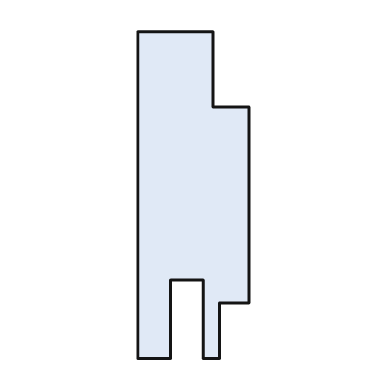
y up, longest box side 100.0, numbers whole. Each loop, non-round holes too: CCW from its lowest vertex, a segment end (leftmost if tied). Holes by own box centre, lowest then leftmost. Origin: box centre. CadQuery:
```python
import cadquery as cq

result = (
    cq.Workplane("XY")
    .moveTo(-17.0, -50.0)
    .lineTo(-7.0, -50.0)
    .lineTo(-7.0, -26.0)
    .lineTo(3.0, -26.0)
    .lineTo(3.0, -50.0)
    .lineTo(8.0, -50.0)
    .lineTo(8.0, -33.0)
    .lineTo(17.0, -33.0)
    .lineTo(17.0, 27.0)
    .lineTo(6.0, 27.0)
    .lineTo(6.0, 50.0)
    .lineTo(-17.0, 50.0)
    .close()
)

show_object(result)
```